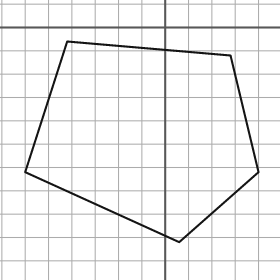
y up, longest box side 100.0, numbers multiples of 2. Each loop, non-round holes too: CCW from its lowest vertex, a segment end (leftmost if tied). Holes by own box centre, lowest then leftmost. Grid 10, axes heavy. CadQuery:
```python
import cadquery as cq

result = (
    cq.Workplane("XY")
    .moveTo(6.0, -92.0)
    .lineTo(40.0, -62.0)
    .lineTo(28.0, -12.0)
    .lineTo(-42.0, -6.0)
    .lineTo(-60.0, -62.0)
    .close()
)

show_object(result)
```